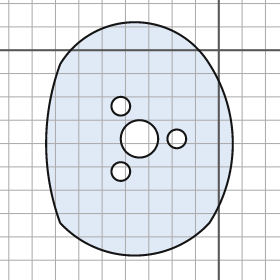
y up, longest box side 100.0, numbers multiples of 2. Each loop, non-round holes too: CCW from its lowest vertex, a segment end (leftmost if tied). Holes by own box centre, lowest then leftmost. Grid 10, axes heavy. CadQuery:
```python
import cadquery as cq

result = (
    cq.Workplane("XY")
    .moveTo(-68.0, -74.0)
    .threePointArc((-36.0, -88.0), (-4.0, -74.0))
    .threePointArc((6.0, -40.0), (-4.0, -6.0))
    .threePointArc((-36.0, 12.0), (-68.0, -6.0))
    .threePointArc((-74.0, -40.0), (-68.0, -74.0))
    .close()
    .moveTo(-42.0, -52.0)
    .circle(4.0)
    .moveTo(-34.0, -38.0)
    .circle(8.0)
    .moveTo(-18.0, -38.0)
    .circle(4.0)
    .moveTo(-42.0, -24.0)
    .circle(4.0)
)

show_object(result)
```